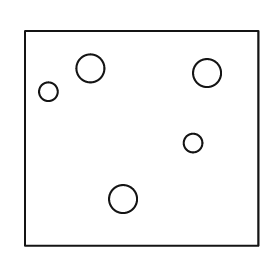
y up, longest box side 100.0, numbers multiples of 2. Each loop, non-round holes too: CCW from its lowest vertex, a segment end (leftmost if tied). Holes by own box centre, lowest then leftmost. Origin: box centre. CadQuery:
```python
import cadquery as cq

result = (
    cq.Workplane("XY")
    .moveTo(-50.0, -46.0)
    .lineTo(50.0, -46.0)
    .lineTo(50.0, 46.0)
    .lineTo(-50.0, 46.0)
    .close()
    .moveTo(-8.0, -26.0)
    .circle(6.0)
    .moveTo(22.0, -2.0)
    .circle(4.0)
    .moveTo(-40.0, 20.0)
    .circle(4.0)
    .moveTo(28.0, 28.0)
    .circle(6.0)
    .moveTo(-22.0, 30.0)
    .circle(6.0)
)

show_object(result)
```